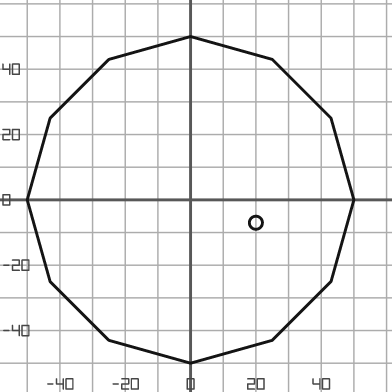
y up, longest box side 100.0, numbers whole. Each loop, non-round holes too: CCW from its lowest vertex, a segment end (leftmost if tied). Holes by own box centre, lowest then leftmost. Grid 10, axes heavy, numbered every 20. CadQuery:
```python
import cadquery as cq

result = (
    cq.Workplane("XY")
    .moveTo(0.0, -50.0)
    .lineTo(25.0, -43.0)
    .lineTo(43.0, -25.0)
    .lineTo(50.0, 0.0)
    .lineTo(43.0, 25.0)
    .lineTo(25.0, 43.0)
    .lineTo(0.0, 50.0)
    .lineTo(-25.0, 43.0)
    .lineTo(-43.0, 25.0)
    .lineTo(-50.0, 0.0)
    .lineTo(-43.0, -25.0)
    .lineTo(-25.0, -43.0)
    .close()
    .moveTo(20.0, -7.0)
    .circle(2.0)
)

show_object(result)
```